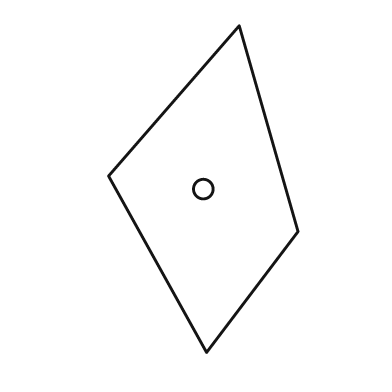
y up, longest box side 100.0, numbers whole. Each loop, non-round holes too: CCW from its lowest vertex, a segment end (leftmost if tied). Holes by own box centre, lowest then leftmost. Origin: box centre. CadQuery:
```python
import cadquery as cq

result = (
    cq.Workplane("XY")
    .moveTo(1.0, -50.0)
    .lineTo(29.0, -13.0)
    .lineTo(11.0, 50.0)
    .lineTo(-29.0, 4.0)
    .close()
    .moveTo(0.0, 0.0)
    .circle(3.0)
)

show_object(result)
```